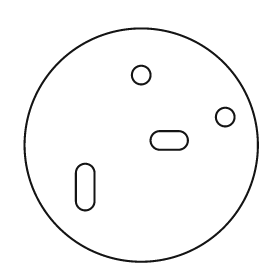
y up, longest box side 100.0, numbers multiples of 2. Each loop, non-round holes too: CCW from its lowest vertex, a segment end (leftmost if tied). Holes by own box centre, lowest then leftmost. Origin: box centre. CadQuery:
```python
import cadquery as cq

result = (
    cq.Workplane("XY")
    .moveTo(0.0, 0.0)
    .circle(50.0)
    .moveTo(-28.0, -24.0)
    .threePointArc((-24.0, -28.0), (-20.0, -24.0))
    .lineTo(-20.0, -12.0)
    .threePointArc((-24.0, -8.0), (-28.0, -12.0))
    .close()
    .moveTo(8.0, -2.0)
    .lineTo(16.0, -2.0)
    .threePointArc((20.0, 2.0), (16.0, 6.0))
    .lineTo(8.0, 6.0)
    .threePointArc((4.0, 2.0), (8.0, -2.0))
    .close()
    .moveTo(36.0, 12.0)
    .circle(4.0)
    .moveTo(0.0, 30.0)
    .circle(4.0)
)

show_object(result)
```